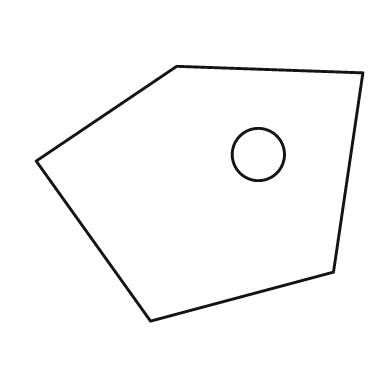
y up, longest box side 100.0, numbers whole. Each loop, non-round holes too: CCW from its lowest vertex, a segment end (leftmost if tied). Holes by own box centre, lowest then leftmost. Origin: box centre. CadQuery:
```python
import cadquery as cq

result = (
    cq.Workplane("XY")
    .moveTo(-15.0, -39.0)
    .lineTo(41.0, -24.0)
    .lineTo(50.0, 37.0)
    .lineTo(-7.0, 39.0)
    .lineTo(-50.0, 10.0)
    .close()
    .moveTo(18.0, 12.0)
    .circle(8.0)
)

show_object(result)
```